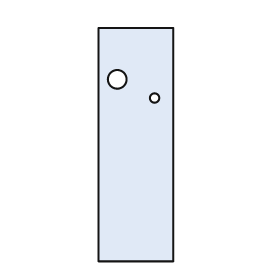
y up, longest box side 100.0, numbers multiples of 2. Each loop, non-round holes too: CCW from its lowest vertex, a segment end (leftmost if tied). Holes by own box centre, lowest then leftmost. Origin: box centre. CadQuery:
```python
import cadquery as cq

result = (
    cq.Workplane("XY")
    .moveTo(-16.0, -50.0)
    .lineTo(16.0, -50.0)
    .lineTo(16.0, 50.0)
    .lineTo(-16.0, 50.0)
    .close()
    .moveTo(8.0, 20.0)
    .circle(2.0)
    .moveTo(-8.0, 28.0)
    .circle(4.0)
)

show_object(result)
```